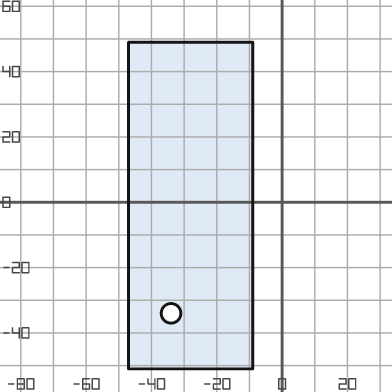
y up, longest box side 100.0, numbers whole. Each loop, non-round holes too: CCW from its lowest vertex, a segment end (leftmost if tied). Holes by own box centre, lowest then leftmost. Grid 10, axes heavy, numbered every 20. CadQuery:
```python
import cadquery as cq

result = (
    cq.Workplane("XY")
    .moveTo(-47.0, -51.0)
    .lineTo(-9.0, -51.0)
    .lineTo(-9.0, 49.0)
    .lineTo(-47.0, 49.0)
    .close()
    .moveTo(-34.0, -34.0)
    .circle(3.0)
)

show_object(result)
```